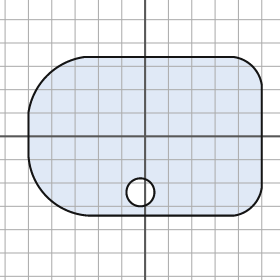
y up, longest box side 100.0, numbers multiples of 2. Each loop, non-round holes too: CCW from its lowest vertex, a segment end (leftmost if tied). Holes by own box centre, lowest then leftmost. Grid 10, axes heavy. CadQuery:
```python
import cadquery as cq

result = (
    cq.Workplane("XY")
    .moveTo(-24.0, -34.0)
    .lineTo(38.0, -34.0)
    .threePointArc((46.0, -30.0), (50.0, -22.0))
    .lineTo(50.0, 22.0)
    .threePointArc((46.0, 30.0), (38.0, 34.0))
    .lineTo(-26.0, 34.0)
    .threePointArc((-42.0, 26.0), (-50.0, 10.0))
    .lineTo(-50.0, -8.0)
    .threePointArc((-42.0, -26.0), (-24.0, -34.0))
    .close()
    .moveTo(-2.0, -24.0)
    .circle(6.0)
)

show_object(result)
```